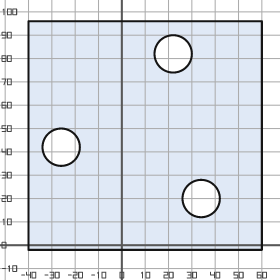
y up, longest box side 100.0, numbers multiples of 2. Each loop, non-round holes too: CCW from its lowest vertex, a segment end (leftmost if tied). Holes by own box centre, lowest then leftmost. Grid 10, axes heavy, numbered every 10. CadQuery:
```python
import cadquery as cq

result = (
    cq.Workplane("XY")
    .moveTo(-40.0, -2.0)
    .lineTo(60.0, -2.0)
    .lineTo(60.0, 96.0)
    .lineTo(-40.0, 96.0)
    .close()
    .moveTo(34.0, 20.0)
    .circle(8.0)
    .moveTo(-26.0, 42.0)
    .circle(8.0)
    .moveTo(22.0, 82.0)
    .circle(8.0)
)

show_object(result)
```